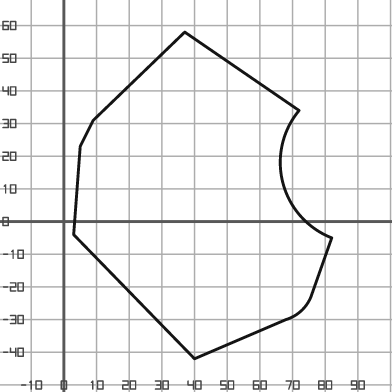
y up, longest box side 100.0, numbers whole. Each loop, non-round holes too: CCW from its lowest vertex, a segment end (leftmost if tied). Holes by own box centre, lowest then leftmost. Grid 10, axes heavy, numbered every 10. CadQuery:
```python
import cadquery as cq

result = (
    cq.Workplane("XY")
    .moveTo(40.0, -42.0)
    .lineTo(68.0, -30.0)
    .threePointArc((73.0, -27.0), (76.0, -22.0))
    .lineTo(82.0, -5.0)
    .threePointArc((67.0, 12.0), (72.0, 34.0))
    .lineTo(37.0, 58.0)
    .lineTo(9.0, 31.0)
    .lineTo(5.0, 23.0)
    .lineTo(3.0, -4.0)
    .close()
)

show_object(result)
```